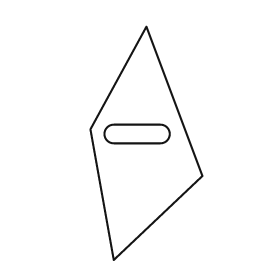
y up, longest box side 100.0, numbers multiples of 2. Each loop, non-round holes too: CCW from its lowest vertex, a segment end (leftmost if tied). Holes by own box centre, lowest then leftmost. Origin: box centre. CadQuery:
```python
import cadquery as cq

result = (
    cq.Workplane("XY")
    .moveTo(-14.0, -50.0)
    .lineTo(24.0, -14.0)
    .lineTo(0.0, 50.0)
    .lineTo(-24.0, 6.0)
    .close()
    .moveTo(-14.0, 0.0)
    .lineTo(6.0, 0.0)
    .threePointArc((10.0, 4.0), (6.0, 8.0))
    .lineTo(-14.0, 8.0)
    .threePointArc((-18.0, 4.0), (-14.0, 0.0))
    .close()
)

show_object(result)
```